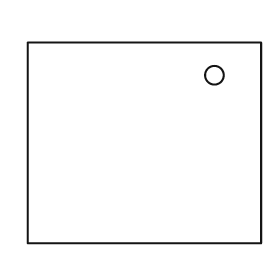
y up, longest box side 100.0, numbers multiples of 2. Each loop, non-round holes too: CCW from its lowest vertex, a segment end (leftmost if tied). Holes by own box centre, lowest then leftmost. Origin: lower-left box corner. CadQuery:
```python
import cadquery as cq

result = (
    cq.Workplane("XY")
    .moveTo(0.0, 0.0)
    .lineTo(100.0, 0.0)
    .lineTo(100.0, 86.0)
    .lineTo(0.0, 86.0)
    .close()
    .moveTo(80.0, 72.0)
    .circle(4.0)
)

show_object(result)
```